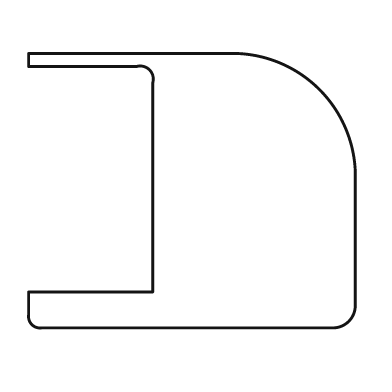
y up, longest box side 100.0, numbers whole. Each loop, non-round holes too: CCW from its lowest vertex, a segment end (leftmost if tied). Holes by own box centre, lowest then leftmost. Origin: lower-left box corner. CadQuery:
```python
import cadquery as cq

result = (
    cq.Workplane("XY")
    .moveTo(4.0, 0.0)
    .lineTo(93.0, 0.0)
    .threePointArc((98.0, 2.0), (100.0, 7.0))
    .lineTo(100.0, 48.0)
    .threePointArc((89.0, 73.0), (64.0, 84.0))
    .lineTo(0.0, 84.0)
    .lineTo(0.0, 80.0)
    .lineTo(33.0, 80.0)
    .threePointArc((37.0, 79.0), (38.0, 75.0))
    .lineTo(38.0, 11.0)
    .lineTo(0.0, 11.0)
    .lineTo(0.0, 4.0)
    .threePointArc((1.0, 1.0), (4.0, 0.0))
    .close()
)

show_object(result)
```